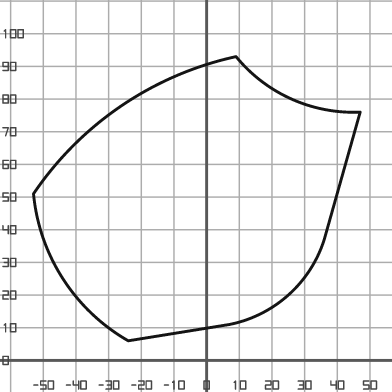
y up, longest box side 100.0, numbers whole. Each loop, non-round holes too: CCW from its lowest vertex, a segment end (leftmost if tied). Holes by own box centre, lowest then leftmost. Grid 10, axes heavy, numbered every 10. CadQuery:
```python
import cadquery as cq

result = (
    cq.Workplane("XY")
    .moveTo(-24.0, 6.0)
    .lineTo(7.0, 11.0)
    .threePointArc((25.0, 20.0), (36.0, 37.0))
    .lineTo(47.0, 76.0)
    .threePointArc((26.0, 80.0), (9.0, 93.0))
    .threePointArc((-26.0, 78.0), (-53.0, 51.0))
    .threePointArc((-44.0, 25.0), (-24.0, 6.0))
    .close()
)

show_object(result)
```